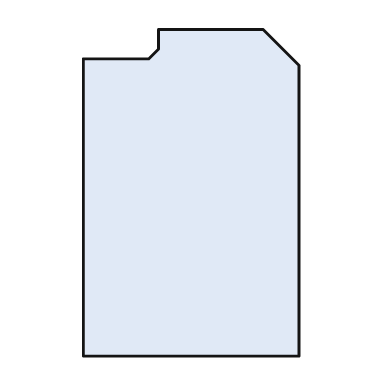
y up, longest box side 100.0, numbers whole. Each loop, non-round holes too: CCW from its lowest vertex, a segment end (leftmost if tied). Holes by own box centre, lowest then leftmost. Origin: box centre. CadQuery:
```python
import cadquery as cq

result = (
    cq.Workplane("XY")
    .moveTo(-33.0, -50.0)
    .lineTo(33.0, -50.0)
    .lineTo(33.0, 39.0)
    .lineTo(22.0, 50.0)
    .lineTo(-10.0, 50.0)
    .lineTo(-10.0, 44.0)
    .lineTo(-13.0, 41.0)
    .lineTo(-33.0, 41.0)
    .close()
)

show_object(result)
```